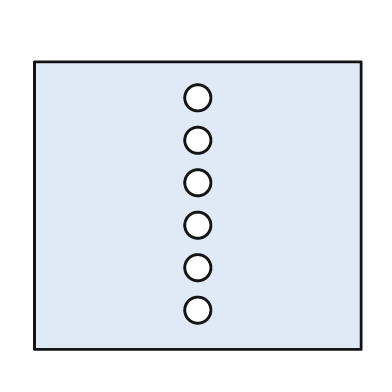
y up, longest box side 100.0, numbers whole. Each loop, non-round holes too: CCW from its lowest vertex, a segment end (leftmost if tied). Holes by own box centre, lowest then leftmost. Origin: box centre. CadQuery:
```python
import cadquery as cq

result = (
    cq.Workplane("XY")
    .moveTo(-50.0, -44.0)
    .lineTo(50.0, -44.0)
    .lineTo(50.0, 44.0)
    .lineTo(-50.0, 44.0)
    .close()
    .moveTo(0.0, -32.0)
    .circle(4.0)
    .moveTo(0.0, -19.0)
    .circle(4.0)
    .moveTo(0.0, -6.0)
    .circle(4.0)
    .moveTo(0.0, 7.0)
    .circle(4.0)
    .moveTo(0.0, 20.0)
    .circle(4.0)
    .moveTo(0.0, 33.0)
    .circle(4.0)
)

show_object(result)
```